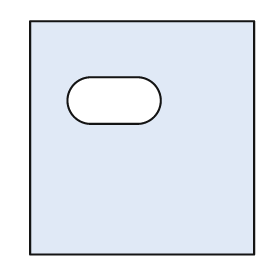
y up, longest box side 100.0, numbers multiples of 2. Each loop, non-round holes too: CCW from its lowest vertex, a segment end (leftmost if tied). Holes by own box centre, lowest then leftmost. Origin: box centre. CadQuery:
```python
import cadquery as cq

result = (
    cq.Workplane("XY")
    .moveTo(-48.0, -50.0)
    .lineTo(48.0, -50.0)
    .lineTo(48.0, 50.0)
    .lineTo(-48.0, 50.0)
    .close()
    .moveTo(-22.0, 6.0)
    .lineTo(-2.0, 6.0)
    .threePointArc((8.0, 16.0), (-2.0, 26.0))
    .lineTo(-22.0, 26.0)
    .threePointArc((-32.0, 16.0), (-22.0, 6.0))
    .close()
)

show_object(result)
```